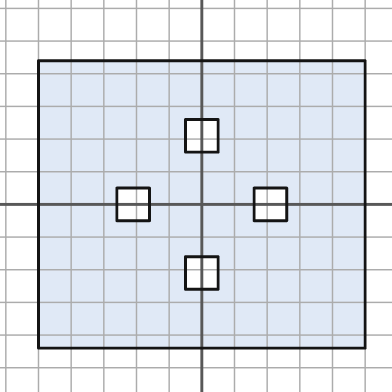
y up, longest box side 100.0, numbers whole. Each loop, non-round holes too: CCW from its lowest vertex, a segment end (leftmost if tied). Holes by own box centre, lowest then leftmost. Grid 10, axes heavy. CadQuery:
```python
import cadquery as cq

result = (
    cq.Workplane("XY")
    .moveTo(-50.0, -44.0)
    .lineTo(50.0, -44.0)
    .lineTo(50.0, 44.0)
    .lineTo(-50.0, 44.0)
    .close()
    .moveTo(-5.0, -26.0)
    .lineTo(5.0, -26.0)
    .lineTo(5.0, -16.0)
    .lineTo(-5.0, -16.0)
    .close()
    .moveTo(-26.0, -5.0)
    .lineTo(-16.0, -5.0)
    .lineTo(-16.0, 5.0)
    .lineTo(-26.0, 5.0)
    .close()
    .moveTo(16.0, -5.0)
    .lineTo(26.0, -5.0)
    .lineTo(26.0, 5.0)
    .lineTo(16.0, 5.0)
    .close()
    .moveTo(-5.0, 16.0)
    .lineTo(5.0, 16.0)
    .lineTo(5.0, 26.0)
    .lineTo(-5.0, 26.0)
    .close()
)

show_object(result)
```